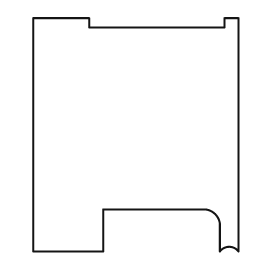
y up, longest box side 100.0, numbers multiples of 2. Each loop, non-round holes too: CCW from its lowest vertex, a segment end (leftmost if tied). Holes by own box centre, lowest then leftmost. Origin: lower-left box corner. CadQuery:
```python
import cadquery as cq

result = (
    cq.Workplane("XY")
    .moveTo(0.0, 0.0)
    .lineTo(30.0, 0.0)
    .lineTo(30.0, 18.0)
    .lineTo(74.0, 18.0)
    .threePointArc((78.0, 16.0), (80.0, 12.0))
    .lineTo(80.0, 0.0)
    .threePointArc((84.0, 2.0), (88.0, 0.0))
    .lineTo(88.0, 100.0)
    .lineTo(82.0, 100.0)
    .lineTo(82.0, 96.0)
    .lineTo(24.0, 96.0)
    .lineTo(24.0, 100.0)
    .lineTo(0.0, 100.0)
    .close()
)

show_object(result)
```